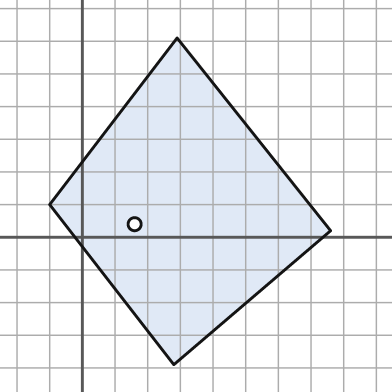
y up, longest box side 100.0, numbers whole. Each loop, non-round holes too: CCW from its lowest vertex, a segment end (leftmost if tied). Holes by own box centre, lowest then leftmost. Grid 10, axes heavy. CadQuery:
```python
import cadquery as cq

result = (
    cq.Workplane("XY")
    .moveTo(28.0, -39.0)
    .lineTo(76.0, 2.0)
    .lineTo(29.0, 61.0)
    .lineTo(-10.0, 10.0)
    .close()
    .moveTo(16.0, 4.0)
    .circle(2.0)
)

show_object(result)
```